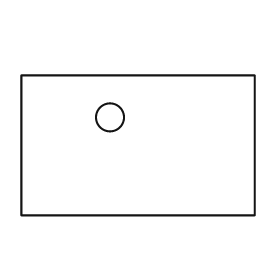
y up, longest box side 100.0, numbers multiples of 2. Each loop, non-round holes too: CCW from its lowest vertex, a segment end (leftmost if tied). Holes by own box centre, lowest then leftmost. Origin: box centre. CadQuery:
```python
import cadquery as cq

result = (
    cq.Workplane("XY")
    .moveTo(-50.0, -30.0)
    .lineTo(50.0, -30.0)
    .lineTo(50.0, 30.0)
    .lineTo(-50.0, 30.0)
    .close()
    .moveTo(-12.0, 12.0)
    .circle(6.0)
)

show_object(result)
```